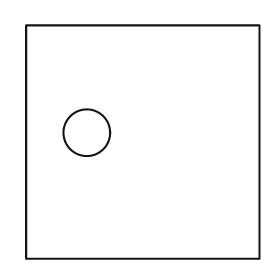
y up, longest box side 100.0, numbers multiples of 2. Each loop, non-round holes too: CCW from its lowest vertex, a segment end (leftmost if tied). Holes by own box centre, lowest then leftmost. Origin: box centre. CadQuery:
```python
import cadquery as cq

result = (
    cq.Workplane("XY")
    .moveTo(-50.0, -50.0)
    .lineTo(50.0, -50.0)
    .lineTo(50.0, 50.0)
    .lineTo(-50.0, 50.0)
    .close()
    .moveTo(-24.0, 4.0)
    .circle(10.0)
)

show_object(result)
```